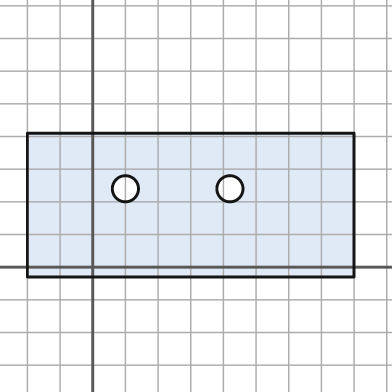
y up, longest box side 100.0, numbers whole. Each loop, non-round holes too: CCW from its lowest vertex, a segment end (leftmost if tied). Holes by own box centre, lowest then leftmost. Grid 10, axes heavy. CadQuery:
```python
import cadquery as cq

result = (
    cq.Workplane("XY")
    .moveTo(-20.0, -3.0)
    .lineTo(80.0, -3.0)
    .lineTo(80.0, 41.0)
    .lineTo(-20.0, 41.0)
    .close()
    .moveTo(10.0, 24.0)
    .circle(4.0)
    .moveTo(42.0, 24.0)
    .circle(4.0)
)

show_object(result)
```